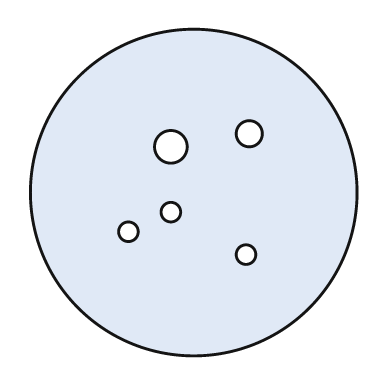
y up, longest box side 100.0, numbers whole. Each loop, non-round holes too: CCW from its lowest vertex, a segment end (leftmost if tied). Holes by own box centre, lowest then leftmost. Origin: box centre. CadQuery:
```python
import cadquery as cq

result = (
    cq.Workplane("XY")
    .moveTo(0.0, 0.0)
    .circle(50.0)
    .moveTo(16.0, -19.0)
    .circle(3.0)
    .moveTo(-20.0, -12.0)
    .circle(3.0)
    .moveTo(-7.0, -6.0)
    .circle(3.0)
    .moveTo(-7.0, 14.0)
    .circle(5.0)
    .moveTo(17.0, 18.0)
    .circle(4.0)
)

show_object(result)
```